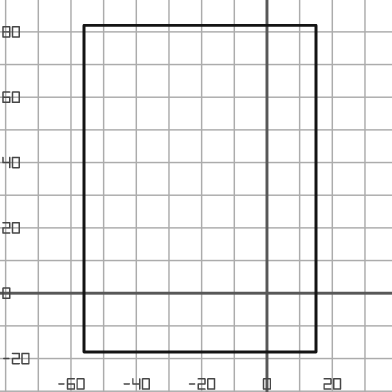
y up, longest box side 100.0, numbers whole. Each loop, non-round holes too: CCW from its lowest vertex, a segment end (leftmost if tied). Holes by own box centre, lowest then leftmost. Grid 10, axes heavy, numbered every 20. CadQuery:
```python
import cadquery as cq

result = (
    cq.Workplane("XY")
    .moveTo(-56.0, -18.0)
    .lineTo(15.0, -18.0)
    .lineTo(15.0, 82.0)
    .lineTo(-56.0, 82.0)
    .close()
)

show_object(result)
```